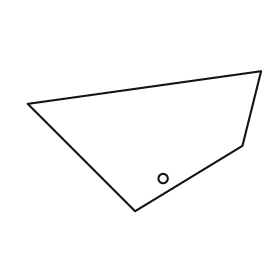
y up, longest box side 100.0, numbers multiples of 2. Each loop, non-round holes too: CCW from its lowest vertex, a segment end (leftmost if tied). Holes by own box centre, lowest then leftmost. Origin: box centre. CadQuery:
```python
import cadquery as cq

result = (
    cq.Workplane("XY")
    .moveTo(-4.0, -30.0)
    .lineTo(42.0, -2.0)
    .lineTo(50.0, 30.0)
    .lineTo(-50.0, 16.0)
    .close()
    .moveTo(8.0, -16.0)
    .circle(2.0)
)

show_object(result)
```